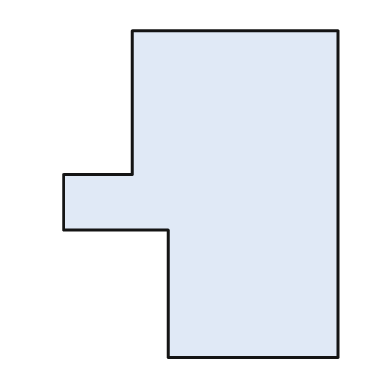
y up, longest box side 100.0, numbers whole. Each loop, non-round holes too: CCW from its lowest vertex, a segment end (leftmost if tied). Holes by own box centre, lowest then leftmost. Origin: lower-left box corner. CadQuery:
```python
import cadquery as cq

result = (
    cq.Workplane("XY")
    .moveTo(32.0, 0.0)
    .lineTo(84.0, 0.0)
    .lineTo(84.0, 100.0)
    .lineTo(21.0, 100.0)
    .lineTo(21.0, 56.0)
    .lineTo(0.0, 56.0)
    .lineTo(0.0, 39.0)
    .lineTo(32.0, 39.0)
    .close()
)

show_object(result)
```